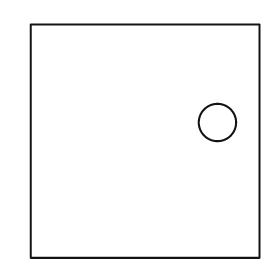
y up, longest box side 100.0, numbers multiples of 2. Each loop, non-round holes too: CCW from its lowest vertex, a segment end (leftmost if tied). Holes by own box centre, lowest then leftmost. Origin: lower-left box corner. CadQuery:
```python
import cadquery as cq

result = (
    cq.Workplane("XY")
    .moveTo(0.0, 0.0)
    .lineTo(98.0, 0.0)
    .lineTo(98.0, 100.0)
    .lineTo(0.0, 100.0)
    .close()
    .moveTo(80.0, 58.0)
    .circle(8.0)
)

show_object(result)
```